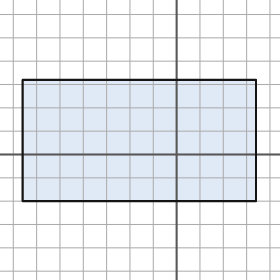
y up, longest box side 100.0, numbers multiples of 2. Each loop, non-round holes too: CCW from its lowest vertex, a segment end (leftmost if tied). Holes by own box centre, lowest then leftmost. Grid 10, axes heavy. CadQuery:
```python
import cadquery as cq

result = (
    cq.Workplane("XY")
    .moveTo(-66.0, -20.0)
    .lineTo(34.0, -20.0)
    .lineTo(34.0, 32.0)
    .lineTo(-66.0, 32.0)
    .close()
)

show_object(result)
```